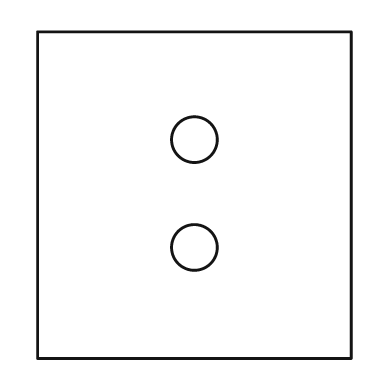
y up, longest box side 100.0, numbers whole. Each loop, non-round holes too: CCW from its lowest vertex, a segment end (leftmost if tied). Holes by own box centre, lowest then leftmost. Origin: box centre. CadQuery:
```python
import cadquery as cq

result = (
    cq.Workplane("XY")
    .moveTo(-48.0, -50.0)
    .lineTo(48.0, -50.0)
    .lineTo(48.0, 50.0)
    .lineTo(-48.0, 50.0)
    .close()
    .moveTo(0.0, -16.0)
    .circle(7.0)
    .moveTo(0.0, 17.0)
    .circle(7.0)
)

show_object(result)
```